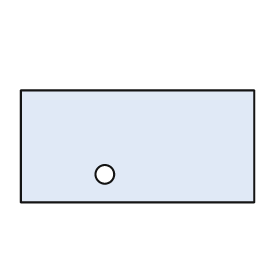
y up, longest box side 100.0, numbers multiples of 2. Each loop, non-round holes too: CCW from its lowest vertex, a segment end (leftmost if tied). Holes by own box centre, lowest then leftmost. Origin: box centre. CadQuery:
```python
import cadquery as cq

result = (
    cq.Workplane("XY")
    .moveTo(-50.0, -24.0)
    .lineTo(50.0, -24.0)
    .lineTo(50.0, 24.0)
    .lineTo(-50.0, 24.0)
    .close()
    .moveTo(-14.0, -12.0)
    .circle(4.0)
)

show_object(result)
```